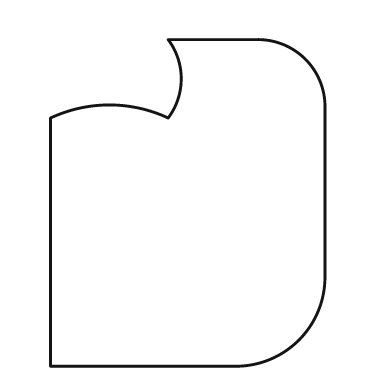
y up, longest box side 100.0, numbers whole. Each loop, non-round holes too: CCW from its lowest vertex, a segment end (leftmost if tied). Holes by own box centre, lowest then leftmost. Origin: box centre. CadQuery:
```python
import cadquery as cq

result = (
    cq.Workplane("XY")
    .moveTo(-42.0, -50.0)
    .lineTo(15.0, -50.0)
    .threePointArc((34.0, -42.0), (42.0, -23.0))
    .lineTo(42.0, 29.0)
    .threePointArc((36.0, 44.0), (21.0, 50.0))
    .lineTo(-6.0, 50.0)
    .threePointArc((-2.0, 38.0), (-6.0, 26.0))
    .threePointArc((-24.0, 30.0), (-42.0, 26.0))
    .close()
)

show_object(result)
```